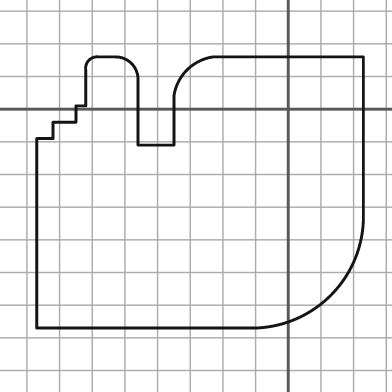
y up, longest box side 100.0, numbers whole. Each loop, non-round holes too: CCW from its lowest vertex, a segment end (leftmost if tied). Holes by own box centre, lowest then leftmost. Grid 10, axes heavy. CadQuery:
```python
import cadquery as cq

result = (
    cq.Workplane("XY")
    .moveTo(-77.0, -67.0)
    .lineTo(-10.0, -67.0)
    .threePointArc((13.0, -57.0), (23.0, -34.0))
    .lineTo(23.0, 16.0)
    .lineTo(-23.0, 16.0)
    .threePointArc((-31.0, 12.0), (-35.0, 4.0))
    .lineTo(-35.0, -11.0)
    .lineTo(-46.0, -11.0)
    .lineTo(-46.0, 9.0)
    .threePointArc((-48.0, 14.0), (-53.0, 16.0))
    .lineTo(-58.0, 16.0)
    .threePointArc((-61.0, 15.0), (-62.0, 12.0))
    .lineTo(-62.0, 1.0)
    .lineTo(-65.0, 1.0)
    .lineTo(-65.0, -4.0)
    .lineTo(-72.0, -4.0)
    .lineTo(-72.0, -9.0)
    .lineTo(-77.0, -9.0)
    .close()
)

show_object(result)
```